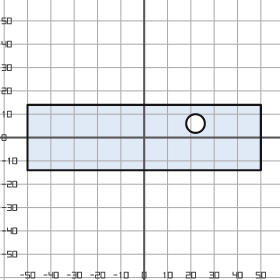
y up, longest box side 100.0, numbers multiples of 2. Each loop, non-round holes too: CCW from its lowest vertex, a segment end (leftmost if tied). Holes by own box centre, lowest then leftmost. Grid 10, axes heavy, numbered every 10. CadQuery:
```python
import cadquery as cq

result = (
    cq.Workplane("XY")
    .moveTo(-50.0, -14.0)
    .lineTo(50.0, -14.0)
    .lineTo(50.0, 14.0)
    .lineTo(-50.0, 14.0)
    .close()
    .moveTo(22.0, 6.0)
    .circle(4.0)
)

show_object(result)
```